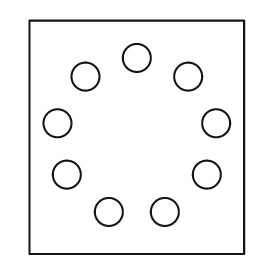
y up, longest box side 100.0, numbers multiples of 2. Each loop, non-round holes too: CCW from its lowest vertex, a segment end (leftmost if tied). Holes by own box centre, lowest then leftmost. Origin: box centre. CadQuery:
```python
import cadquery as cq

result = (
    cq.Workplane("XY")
    .moveTo(-46.0, -50.0)
    .lineTo(46.0, -50.0)
    .lineTo(46.0, 50.0)
    .lineTo(-46.0, 50.0)
    .close()
    .moveTo(-12.0, -32.0)
    .circle(6.0)
    .moveTo(12.0, -32.0)
    .circle(6.0)
    .moveTo(-30.0, -16.0)
    .circle(6.0)
    .moveTo(30.0, -16.0)
    .circle(6.0)
    .moveTo(-34.0, 6.0)
    .circle(6.0)
    .moveTo(34.0, 6.0)
    .circle(6.0)
    .moveTo(-22.0, 26.0)
    .circle(6.0)
    .moveTo(22.0, 26.0)
    .circle(6.0)
    .moveTo(0.0, 34.0)
    .circle(6.0)
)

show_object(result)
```